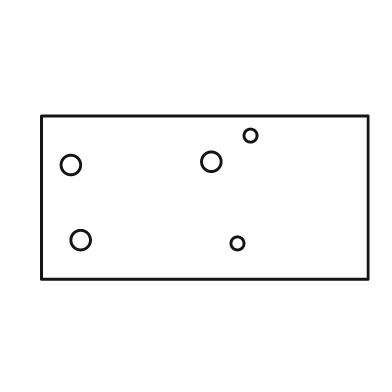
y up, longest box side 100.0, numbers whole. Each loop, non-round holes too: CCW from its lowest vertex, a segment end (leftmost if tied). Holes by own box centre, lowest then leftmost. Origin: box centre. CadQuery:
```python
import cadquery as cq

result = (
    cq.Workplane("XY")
    .moveTo(-50.0, -25.0)
    .lineTo(50.0, -25.0)
    .lineTo(50.0, 25.0)
    .lineTo(-50.0, 25.0)
    .close()
    .moveTo(10.0, -14.0)
    .circle(2.0)
    .moveTo(-38.0, -13.0)
    .circle(3.0)
    .moveTo(-41.0, 10.0)
    .circle(3.0)
    .moveTo(2.0, 11.0)
    .circle(3.0)
    .moveTo(14.0, 19.0)
    .circle(2.0)
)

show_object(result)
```